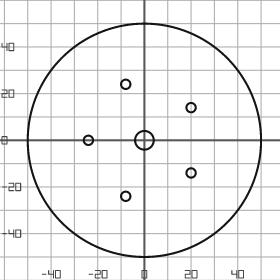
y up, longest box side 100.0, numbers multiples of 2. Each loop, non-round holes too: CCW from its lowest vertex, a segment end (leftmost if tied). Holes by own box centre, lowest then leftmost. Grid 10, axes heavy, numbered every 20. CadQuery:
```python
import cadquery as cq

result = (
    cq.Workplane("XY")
    .moveTo(0.0, 0.0)
    .circle(50.0)
    .moveTo(-8.0, -24.0)
    .circle(2.0)
    .moveTo(20.0, -14.0)
    .circle(2.0)
    .moveTo(-24.0, 0.0)
    .circle(2.0)
    .moveTo(0.0, 0.0)
    .circle(4.0)
    .moveTo(20.0, 14.0)
    .circle(2.0)
    .moveTo(-8.0, 24.0)
    .circle(2.0)
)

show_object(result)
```